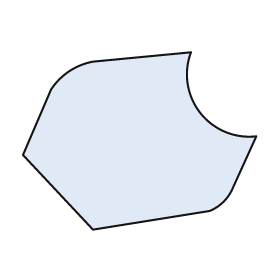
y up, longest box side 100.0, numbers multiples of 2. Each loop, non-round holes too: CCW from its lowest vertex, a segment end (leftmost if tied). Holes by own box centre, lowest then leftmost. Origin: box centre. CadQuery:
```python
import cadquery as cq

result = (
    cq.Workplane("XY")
    .moveTo(-20.0, -38.0)
    .lineTo(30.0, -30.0)
    .threePointArc((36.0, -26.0), (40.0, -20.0))
    .lineTo(50.0, 2.0)
    .threePointArc((26.0, 12.0), (22.0, 38.0))
    .lineTo(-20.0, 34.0)
    .threePointArc((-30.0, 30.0), (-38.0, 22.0))
    .lineTo(-50.0, -6.0)
    .close()
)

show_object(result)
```